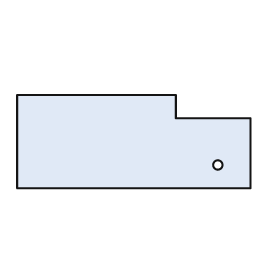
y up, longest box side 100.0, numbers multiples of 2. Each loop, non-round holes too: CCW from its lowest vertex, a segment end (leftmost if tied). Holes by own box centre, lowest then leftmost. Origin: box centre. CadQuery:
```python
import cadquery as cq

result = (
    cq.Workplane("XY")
    .moveTo(-50.0, -20.0)
    .lineTo(50.0, -20.0)
    .lineTo(50.0, 10.0)
    .lineTo(18.0, 10.0)
    .lineTo(18.0, 20.0)
    .lineTo(-50.0, 20.0)
    .close()
    .moveTo(36.0, -10.0)
    .circle(2.0)
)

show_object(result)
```